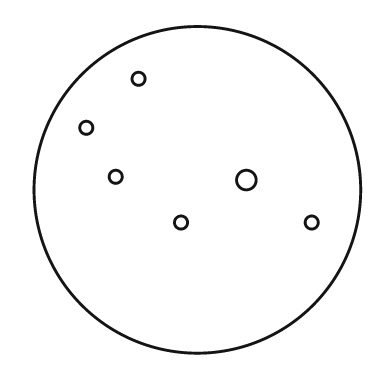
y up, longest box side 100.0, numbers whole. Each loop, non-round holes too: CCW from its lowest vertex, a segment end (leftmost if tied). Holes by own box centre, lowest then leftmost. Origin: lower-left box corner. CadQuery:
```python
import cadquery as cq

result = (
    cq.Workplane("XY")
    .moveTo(50.0, 50.0)
    .circle(50.0)
    .moveTo(45.0, 40.0)
    .circle(2.0)
    .moveTo(85.0, 40.0)
    .circle(2.0)
    .moveTo(65.0, 53.0)
    .circle(3.0)
    .moveTo(25.0, 54.0)
    .circle(2.0)
    .moveTo(16.0, 69.0)
    .circle(2.0)
    .moveTo(32.0, 84.0)
    .circle(2.0)
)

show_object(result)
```